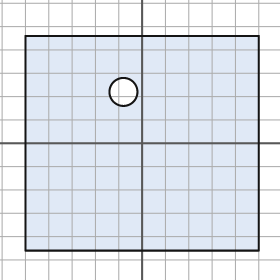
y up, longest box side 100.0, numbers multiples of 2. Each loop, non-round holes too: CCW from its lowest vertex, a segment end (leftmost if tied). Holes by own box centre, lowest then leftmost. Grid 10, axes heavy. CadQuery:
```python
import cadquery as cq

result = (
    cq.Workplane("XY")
    .moveTo(-50.0, -46.0)
    .lineTo(50.0, -46.0)
    .lineTo(50.0, 46.0)
    .lineTo(-50.0, 46.0)
    .close()
    .moveTo(-8.0, 22.0)
    .circle(6.0)
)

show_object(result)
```